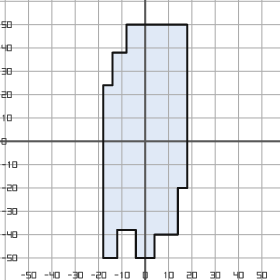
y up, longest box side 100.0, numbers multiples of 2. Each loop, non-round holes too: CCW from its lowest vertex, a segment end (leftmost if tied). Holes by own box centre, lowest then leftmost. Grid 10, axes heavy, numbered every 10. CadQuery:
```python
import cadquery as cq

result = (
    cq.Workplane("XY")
    .moveTo(-18.0, -50.0)
    .lineTo(-12.0, -50.0)
    .lineTo(-12.0, -38.0)
    .lineTo(-4.0, -38.0)
    .lineTo(-4.0, -50.0)
    .lineTo(4.0, -50.0)
    .lineTo(4.0, -40.0)
    .lineTo(14.0, -40.0)
    .lineTo(14.0, -20.0)
    .lineTo(18.0, -20.0)
    .lineTo(18.0, 50.0)
    .lineTo(-8.0, 50.0)
    .lineTo(-8.0, 38.0)
    .lineTo(-14.0, 38.0)
    .lineTo(-14.0, 24.0)
    .lineTo(-18.0, 24.0)
    .close()
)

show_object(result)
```